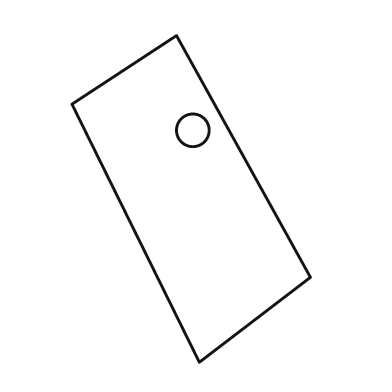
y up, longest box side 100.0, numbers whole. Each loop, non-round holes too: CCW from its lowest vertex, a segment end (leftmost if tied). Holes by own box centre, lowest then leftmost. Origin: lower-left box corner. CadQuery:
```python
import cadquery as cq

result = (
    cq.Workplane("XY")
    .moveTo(39.0, 0.0)
    .lineTo(73.0, 26.0)
    .lineTo(32.0, 100.0)
    .lineTo(0.0, 79.0)
    .close()
    .moveTo(37.0, 71.0)
    .circle(5.0)
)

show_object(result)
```